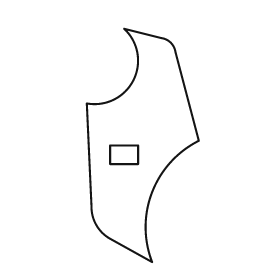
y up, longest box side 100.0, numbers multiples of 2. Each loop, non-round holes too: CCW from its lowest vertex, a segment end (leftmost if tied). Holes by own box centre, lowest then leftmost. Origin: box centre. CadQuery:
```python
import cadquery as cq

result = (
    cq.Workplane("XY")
    .moveTo(4.0, -50.0)
    .threePointArc((4.0, -20.0), (24.0, 2.0))
    .lineTo(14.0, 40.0)
    .threePointArc((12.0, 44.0), (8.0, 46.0))
    .lineTo(-8.0, 50.0)
    .threePointArc((-4.0, 28.0), (-24.0, 18.0))
    .lineTo(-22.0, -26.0)
    .threePointArc((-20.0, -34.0), (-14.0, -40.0))
    .close()
    .moveTo(-14.0, -8.0)
    .lineTo(-2.0, -8.0)
    .lineTo(-2.0, 0.0)
    .lineTo(-14.0, 0.0)
    .close()
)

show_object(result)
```